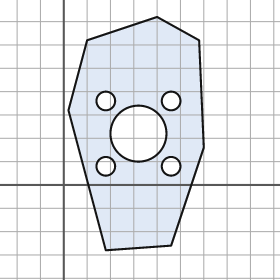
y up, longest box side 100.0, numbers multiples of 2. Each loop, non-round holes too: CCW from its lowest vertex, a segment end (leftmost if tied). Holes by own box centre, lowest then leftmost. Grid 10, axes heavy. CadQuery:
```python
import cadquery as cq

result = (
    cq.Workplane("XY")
    .moveTo(18.0, -28.0)
    .lineTo(46.0, -26.0)
    .lineTo(60.0, 16.0)
    .lineTo(58.0, 62.0)
    .lineTo(40.0, 72.0)
    .lineTo(10.0, 62.0)
    .lineTo(2.0, 32.0)
    .close()
    .moveTo(18.0, 8.0)
    .circle(4.0)
    .moveTo(46.0, 8.0)
    .circle(4.0)
    .moveTo(32.0, 22.0)
    .circle(12.0)
    .moveTo(18.0, 36.0)
    .circle(4.0)
    .moveTo(46.0, 36.0)
    .circle(4.0)
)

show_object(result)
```